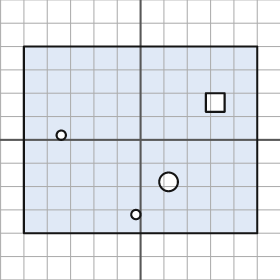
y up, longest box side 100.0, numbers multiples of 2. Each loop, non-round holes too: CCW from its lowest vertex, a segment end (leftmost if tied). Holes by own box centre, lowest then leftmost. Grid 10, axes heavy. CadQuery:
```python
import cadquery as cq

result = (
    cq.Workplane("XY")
    .moveTo(-50.0, -40.0)
    .lineTo(50.0, -40.0)
    .lineTo(50.0, 40.0)
    .lineTo(-50.0, 40.0)
    .close()
    .moveTo(-2.0, -32.0)
    .circle(2.0)
    .moveTo(12.0, -18.0)
    .circle(4.0)
    .moveTo(-34.0, 2.0)
    .circle(2.0)
    .moveTo(28.0, 12.0)
    .lineTo(36.0, 12.0)
    .lineTo(36.0, 20.0)
    .lineTo(28.0, 20.0)
    .close()
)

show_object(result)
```